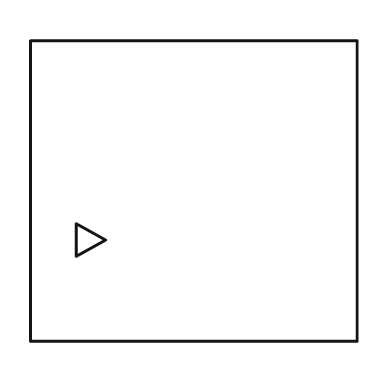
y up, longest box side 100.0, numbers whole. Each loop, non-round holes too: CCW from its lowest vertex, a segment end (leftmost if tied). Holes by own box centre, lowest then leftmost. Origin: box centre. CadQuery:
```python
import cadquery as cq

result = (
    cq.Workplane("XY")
    .moveTo(-50.0, -46.0)
    .lineTo(50.0, -46.0)
    .lineTo(50.0, 46.0)
    .lineTo(-50.0, 46.0)
    .close()
    .moveTo(-36.0, -20.0)
    .lineTo(-27.0, -15.0)
    .lineTo(-36.0, -10.0)
    .close()
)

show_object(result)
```